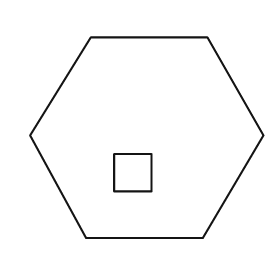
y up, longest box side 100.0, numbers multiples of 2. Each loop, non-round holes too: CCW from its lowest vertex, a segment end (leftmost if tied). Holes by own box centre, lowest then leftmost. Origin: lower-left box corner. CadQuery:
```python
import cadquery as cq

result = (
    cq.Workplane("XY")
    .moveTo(24.0, 0.0)
    .lineTo(74.0, 0.0)
    .lineTo(100.0, 44.0)
    .lineTo(76.0, 86.0)
    .lineTo(26.0, 86.0)
    .lineTo(0.0, 44.0)
    .close()
    .moveTo(36.0, 20.0)
    .lineTo(52.0, 20.0)
    .lineTo(52.0, 36.0)
    .lineTo(36.0, 36.0)
    .close()
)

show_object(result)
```